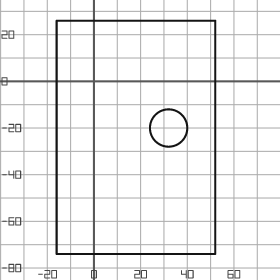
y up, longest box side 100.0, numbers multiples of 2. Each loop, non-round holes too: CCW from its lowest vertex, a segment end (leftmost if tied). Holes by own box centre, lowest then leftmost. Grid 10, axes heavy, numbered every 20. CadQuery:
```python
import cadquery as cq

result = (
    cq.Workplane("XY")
    .moveTo(-16.0, -74.0)
    .lineTo(52.0, -74.0)
    .lineTo(52.0, 26.0)
    .lineTo(-16.0, 26.0)
    .close()
    .moveTo(32.0, -20.0)
    .circle(8.0)
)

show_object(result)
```